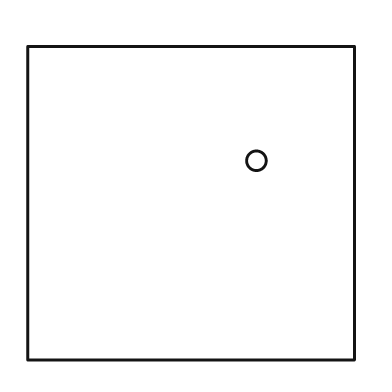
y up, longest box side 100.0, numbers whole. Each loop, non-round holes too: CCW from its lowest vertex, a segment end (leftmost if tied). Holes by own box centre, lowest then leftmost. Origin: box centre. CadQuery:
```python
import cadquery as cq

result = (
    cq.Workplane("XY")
    .moveTo(-50.0, -48.0)
    .lineTo(50.0, -48.0)
    .lineTo(50.0, 48.0)
    .lineTo(-50.0, 48.0)
    .close()
    .moveTo(20.0, 13.0)
    .circle(3.0)
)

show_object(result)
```